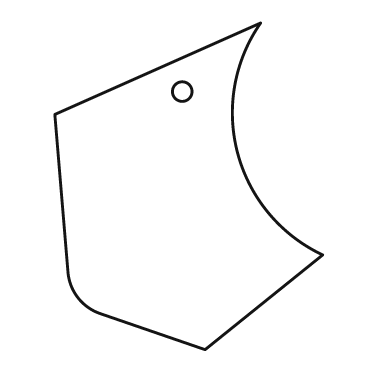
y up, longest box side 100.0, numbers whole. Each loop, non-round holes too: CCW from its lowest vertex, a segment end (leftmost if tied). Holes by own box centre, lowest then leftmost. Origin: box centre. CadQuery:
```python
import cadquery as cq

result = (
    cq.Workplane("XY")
    .moveTo(5.0, -50.0)
    .lineTo(41.0, -21.0)
    .threePointArc((15.0, 10.0), (22.0, 50.0))
    .lineTo(-41.0, 22.0)
    .lineTo(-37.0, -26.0)
    .threePointArc((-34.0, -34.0), (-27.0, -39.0))
    .close()
    .moveTo(-2.0, 29.0)
    .circle(3.0)
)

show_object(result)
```